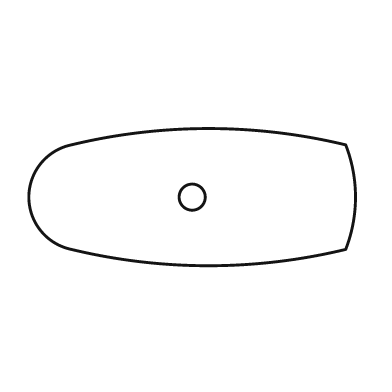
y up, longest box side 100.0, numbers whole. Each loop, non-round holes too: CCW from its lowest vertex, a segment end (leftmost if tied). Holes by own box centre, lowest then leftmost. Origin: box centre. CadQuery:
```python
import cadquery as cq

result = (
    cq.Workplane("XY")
    .moveTo(-37.0, -16.0)
    .threePointArc((5.0, -21.0), (47.0, -16.0))
    .threePointArc((50.0, 0.0), (47.0, 16.0))
    .threePointArc((5.0, 21.0), (-37.0, 16.0))
    .threePointArc((-50.0, 0.0), (-37.0, -16.0))
    .close()
    .moveTo(0.0, 0.0)
    .circle(4.0)
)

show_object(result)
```